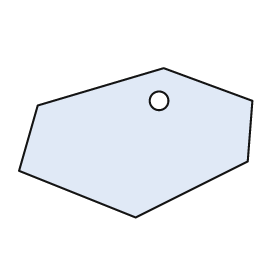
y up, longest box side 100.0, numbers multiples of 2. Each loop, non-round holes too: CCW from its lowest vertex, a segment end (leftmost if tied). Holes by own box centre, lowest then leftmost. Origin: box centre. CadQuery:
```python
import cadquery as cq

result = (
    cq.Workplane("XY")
    .moveTo(0.0, -32.0)
    .lineTo(48.0, -8.0)
    .lineTo(50.0, 18.0)
    .lineTo(12.0, 32.0)
    .lineTo(-42.0, 16.0)
    .lineTo(-50.0, -12.0)
    .close()
    .moveTo(10.0, 18.0)
    .circle(4.0)
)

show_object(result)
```